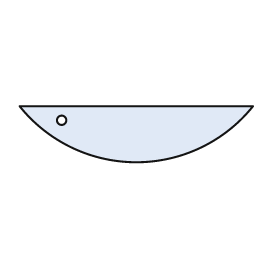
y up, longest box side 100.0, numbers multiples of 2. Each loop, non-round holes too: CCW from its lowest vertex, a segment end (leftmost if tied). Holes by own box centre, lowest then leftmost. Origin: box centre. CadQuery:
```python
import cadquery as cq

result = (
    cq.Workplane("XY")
    .moveTo(-50.0, 12.0)
    .threePointArc((0.0, -12.0), (50.0, 12.0))
    .close()
    .moveTo(-32.0, 6.0)
    .circle(2.0)
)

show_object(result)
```